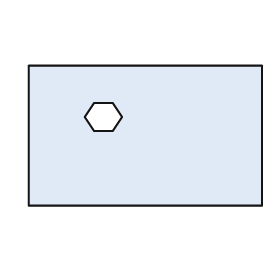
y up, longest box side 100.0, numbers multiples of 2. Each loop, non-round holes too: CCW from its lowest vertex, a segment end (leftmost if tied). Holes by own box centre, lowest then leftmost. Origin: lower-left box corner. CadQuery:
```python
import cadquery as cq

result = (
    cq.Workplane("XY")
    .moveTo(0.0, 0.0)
    .lineTo(100.0, 0.0)
    .lineTo(100.0, 60.0)
    .lineTo(0.0, 60.0)
    .close()
    .moveTo(28.0, 32.0)
    .lineTo(36.0, 32.0)
    .lineTo(40.0, 38.0)
    .lineTo(36.0, 44.0)
    .lineTo(28.0, 44.0)
    .lineTo(24.0, 38.0)
    .close()
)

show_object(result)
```